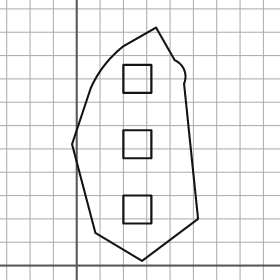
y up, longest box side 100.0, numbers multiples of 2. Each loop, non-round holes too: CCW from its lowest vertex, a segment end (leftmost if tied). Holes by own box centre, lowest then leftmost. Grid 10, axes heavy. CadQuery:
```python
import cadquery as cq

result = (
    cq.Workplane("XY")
    .moveTo(28.0, 2.0)
    .lineTo(52.0, 20.0)
    .lineTo(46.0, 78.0)
    .threePointArc((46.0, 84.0), (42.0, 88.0))
    .lineTo(34.0, 102.0)
    .lineTo(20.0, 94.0)
    .threePointArc((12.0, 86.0), (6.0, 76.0))
    .lineTo(-2.0, 52.0)
    .lineTo(8.0, 14.0)
    .close()
    .moveTo(20.0, 18.0)
    .lineTo(32.0, 18.0)
    .lineTo(32.0, 30.0)
    .lineTo(20.0, 30.0)
    .close()
    .moveTo(20.0, 46.0)
    .lineTo(32.0, 46.0)
    .lineTo(32.0, 58.0)
    .lineTo(20.0, 58.0)
    .close()
    .moveTo(20.0, 74.0)
    .lineTo(32.0, 74.0)
    .lineTo(32.0, 86.0)
    .lineTo(20.0, 86.0)
    .close()
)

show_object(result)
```